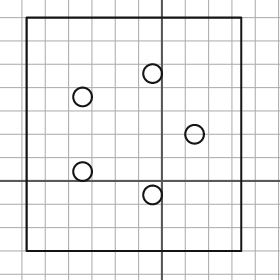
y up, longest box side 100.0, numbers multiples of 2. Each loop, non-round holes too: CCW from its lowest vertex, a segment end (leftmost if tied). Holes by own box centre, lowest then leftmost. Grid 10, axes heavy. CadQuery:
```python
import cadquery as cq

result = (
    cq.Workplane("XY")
    .moveTo(-58.0, -30.0)
    .lineTo(34.0, -30.0)
    .lineTo(34.0, 70.0)
    .lineTo(-58.0, 70.0)
    .close()
    .moveTo(-4.0, -6.0)
    .circle(4.0)
    .moveTo(-34.0, 4.0)
    .circle(4.0)
    .moveTo(14.0, 20.0)
    .circle(4.0)
    .moveTo(-34.0, 36.0)
    .circle(4.0)
    .moveTo(-4.0, 46.0)
    .circle(4.0)
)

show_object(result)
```